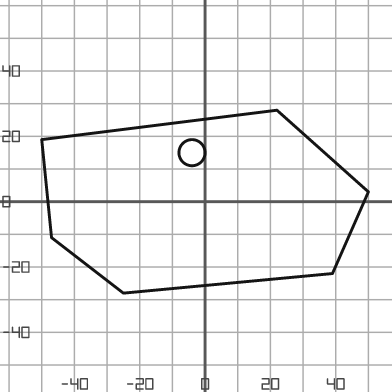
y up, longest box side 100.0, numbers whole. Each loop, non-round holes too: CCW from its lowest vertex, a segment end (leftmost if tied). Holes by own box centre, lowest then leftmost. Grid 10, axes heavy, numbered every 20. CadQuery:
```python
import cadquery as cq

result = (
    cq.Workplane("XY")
    .moveTo(-25.0, -28.0)
    .lineTo(39.0, -22.0)
    .lineTo(50.0, 3.0)
    .lineTo(22.0, 28.0)
    .lineTo(-50.0, 19.0)
    .lineTo(-47.0, -11.0)
    .close()
    .moveTo(-4.0, 15.0)
    .circle(4.0)
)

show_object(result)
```